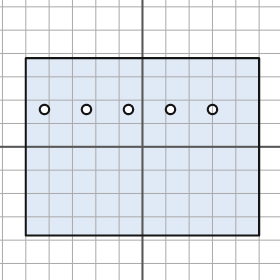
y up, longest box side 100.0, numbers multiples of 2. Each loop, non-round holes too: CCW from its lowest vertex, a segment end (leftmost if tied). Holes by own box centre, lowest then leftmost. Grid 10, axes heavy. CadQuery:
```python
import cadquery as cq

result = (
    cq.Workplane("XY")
    .moveTo(-50.0, -38.0)
    .lineTo(50.0, -38.0)
    .lineTo(50.0, 38.0)
    .lineTo(-50.0, 38.0)
    .close()
    .moveTo(-42.0, 16.0)
    .circle(2.0)
    .moveTo(-24.0, 16.0)
    .circle(2.0)
    .moveTo(-6.0, 16.0)
    .circle(2.0)
    .moveTo(12.0, 16.0)
    .circle(2.0)
    .moveTo(30.0, 16.0)
    .circle(2.0)
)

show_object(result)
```